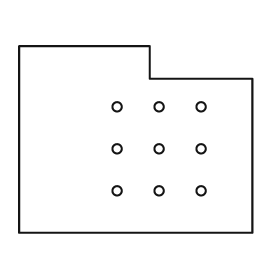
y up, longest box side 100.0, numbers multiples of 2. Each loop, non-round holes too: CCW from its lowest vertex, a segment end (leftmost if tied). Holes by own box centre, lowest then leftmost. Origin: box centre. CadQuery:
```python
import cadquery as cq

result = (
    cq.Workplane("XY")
    .moveTo(-50.0, -40.0)
    .lineTo(50.0, -40.0)
    .lineTo(50.0, 26.0)
    .lineTo(6.0, 26.0)
    .lineTo(6.0, 40.0)
    .lineTo(-50.0, 40.0)
    .close()
    .moveTo(-8.0, -22.0)
    .circle(2.0)
    .moveTo(10.0, -22.0)
    .circle(2.0)
    .moveTo(28.0, -22.0)
    .circle(2.0)
    .moveTo(-8.0, -4.0)
    .circle(2.0)
    .moveTo(10.0, -4.0)
    .circle(2.0)
    .moveTo(28.0, -4.0)
    .circle(2.0)
    .moveTo(-8.0, 14.0)
    .circle(2.0)
    .moveTo(10.0, 14.0)
    .circle(2.0)
    .moveTo(28.0, 14.0)
    .circle(2.0)
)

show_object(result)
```